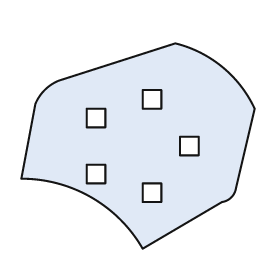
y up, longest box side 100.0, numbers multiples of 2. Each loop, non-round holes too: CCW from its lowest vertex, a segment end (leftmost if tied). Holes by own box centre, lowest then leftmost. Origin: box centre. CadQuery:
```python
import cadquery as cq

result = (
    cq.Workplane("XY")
    .moveTo(2.0, -44.0)
    .lineTo(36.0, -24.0)
    .threePointArc((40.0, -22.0), (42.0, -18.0))
    .lineTo(50.0, 16.0)
    .threePointArc((36.0, 34.0), (16.0, 44.0))
    .lineTo(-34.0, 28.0)
    .threePointArc((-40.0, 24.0), (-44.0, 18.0))
    .lineTo(-50.0, -14.0)
    .threePointArc((-20.0, -22.0), (2.0, -44.0))
    .close()
    .moveTo(2.0, -24.0)
    .lineTo(10.0, -24.0)
    .lineTo(10.0, -16.0)
    .lineTo(2.0, -16.0)
    .close()
    .moveTo(-22.0, -16.0)
    .lineTo(-14.0, -16.0)
    .lineTo(-14.0, -8.0)
    .lineTo(-22.0, -8.0)
    .close()
    .moveTo(18.0, -4.0)
    .lineTo(26.0, -4.0)
    .lineTo(26.0, 4.0)
    .lineTo(18.0, 4.0)
    .close()
    .moveTo(-22.0, 8.0)
    .lineTo(-14.0, 8.0)
    .lineTo(-14.0, 16.0)
    .lineTo(-22.0, 16.0)
    .close()
    .moveTo(2.0, 16.0)
    .lineTo(10.0, 16.0)
    .lineTo(10.0, 24.0)
    .lineTo(2.0, 24.0)
    .close()
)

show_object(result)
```